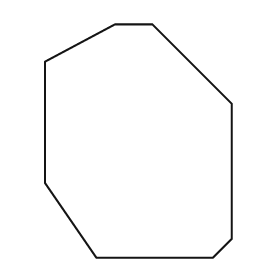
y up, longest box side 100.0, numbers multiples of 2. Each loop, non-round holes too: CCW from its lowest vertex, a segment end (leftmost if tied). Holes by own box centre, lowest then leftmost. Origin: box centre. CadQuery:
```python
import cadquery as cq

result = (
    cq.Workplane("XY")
    .moveTo(-18.0, -50.0)
    .lineTo(32.0, -50.0)
    .lineTo(40.0, -42.0)
    .lineTo(40.0, 16.0)
    .lineTo(6.0, 50.0)
    .lineTo(-10.0, 50.0)
    .lineTo(-40.0, 34.0)
    .lineTo(-40.0, -18.0)
    .close()
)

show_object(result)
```